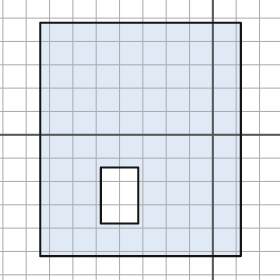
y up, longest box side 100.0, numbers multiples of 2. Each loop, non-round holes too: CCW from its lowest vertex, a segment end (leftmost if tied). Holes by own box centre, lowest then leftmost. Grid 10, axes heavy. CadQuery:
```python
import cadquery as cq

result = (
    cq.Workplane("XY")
    .moveTo(-74.0, -52.0)
    .lineTo(12.0, -52.0)
    .lineTo(12.0, 48.0)
    .lineTo(-74.0, 48.0)
    .close()
    .moveTo(-48.0, -38.0)
    .lineTo(-32.0, -38.0)
    .lineTo(-32.0, -14.0)
    .lineTo(-48.0, -14.0)
    .close()
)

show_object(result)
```